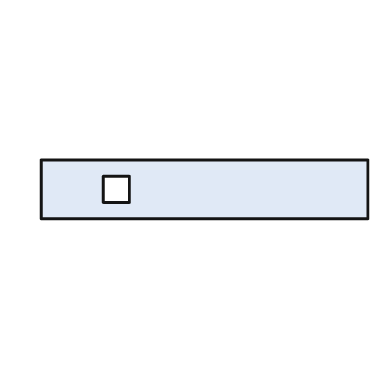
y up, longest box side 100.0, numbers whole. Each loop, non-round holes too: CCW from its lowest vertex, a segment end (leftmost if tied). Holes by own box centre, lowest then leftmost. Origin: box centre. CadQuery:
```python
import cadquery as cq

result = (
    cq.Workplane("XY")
    .moveTo(-50.0, -9.0)
    .lineTo(50.0, -9.0)
    .lineTo(50.0, 9.0)
    .lineTo(-50.0, 9.0)
    .close()
    .moveTo(-31.0, -4.0)
    .lineTo(-23.0, -4.0)
    .lineTo(-23.0, 4.0)
    .lineTo(-31.0, 4.0)
    .close()
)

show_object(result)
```